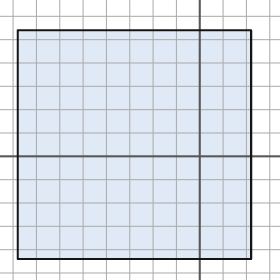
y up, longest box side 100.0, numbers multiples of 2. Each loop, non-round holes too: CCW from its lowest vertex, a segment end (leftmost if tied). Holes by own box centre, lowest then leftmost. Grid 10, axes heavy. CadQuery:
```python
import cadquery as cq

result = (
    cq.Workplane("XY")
    .moveTo(-78.0, -44.0)
    .lineTo(22.0, -44.0)
    .lineTo(22.0, 54.0)
    .lineTo(-78.0, 54.0)
    .close()
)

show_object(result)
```